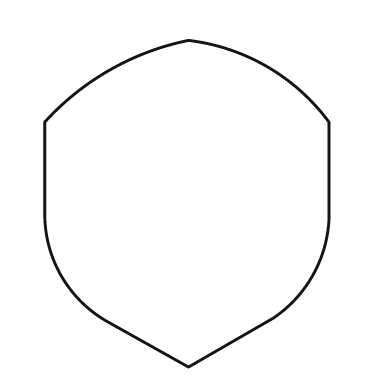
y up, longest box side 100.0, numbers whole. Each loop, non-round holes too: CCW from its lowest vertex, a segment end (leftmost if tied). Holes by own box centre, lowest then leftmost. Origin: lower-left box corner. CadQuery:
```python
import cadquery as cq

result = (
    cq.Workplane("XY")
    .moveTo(44.0, 0.0)
    .lineTo(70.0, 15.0)
    .threePointArc((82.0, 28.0), (87.0, 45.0))
    .lineTo(87.0, 75.0)
    .threePointArc((68.0, 92.0), (44.0, 100.0))
    .threePointArc((20.0, 91.0), (0.0, 75.0))
    .lineTo(0.0, 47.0)
    .threePointArc((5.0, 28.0), (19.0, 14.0))
    .close()
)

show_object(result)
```